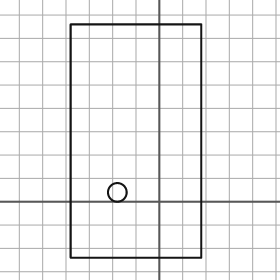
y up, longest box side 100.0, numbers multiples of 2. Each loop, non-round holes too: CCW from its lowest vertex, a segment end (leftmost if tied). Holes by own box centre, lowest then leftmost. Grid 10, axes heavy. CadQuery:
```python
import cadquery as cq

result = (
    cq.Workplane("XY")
    .moveTo(-38.0, -24.0)
    .lineTo(18.0, -24.0)
    .lineTo(18.0, 76.0)
    .lineTo(-38.0, 76.0)
    .close()
    .moveTo(-18.0, 4.0)
    .circle(4.0)
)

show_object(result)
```